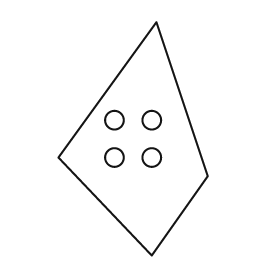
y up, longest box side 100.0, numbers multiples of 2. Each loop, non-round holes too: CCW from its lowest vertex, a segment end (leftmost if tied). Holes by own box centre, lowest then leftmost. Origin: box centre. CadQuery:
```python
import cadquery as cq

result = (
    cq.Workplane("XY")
    .moveTo(8.0, -50.0)
    .lineTo(32.0, -16.0)
    .lineTo(10.0, 50.0)
    .lineTo(-32.0, -8.0)
    .close()
    .moveTo(-8.0, -8.0)
    .circle(4.0)
    .moveTo(8.0, -8.0)
    .circle(4.0)
    .moveTo(-8.0, 8.0)
    .circle(4.0)
    .moveTo(8.0, 8.0)
    .circle(4.0)
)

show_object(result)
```